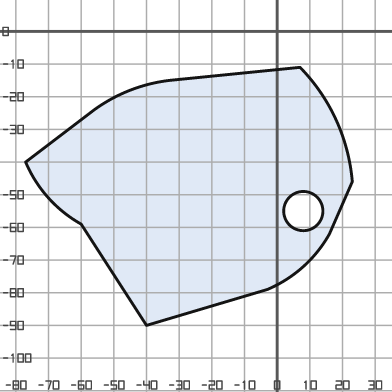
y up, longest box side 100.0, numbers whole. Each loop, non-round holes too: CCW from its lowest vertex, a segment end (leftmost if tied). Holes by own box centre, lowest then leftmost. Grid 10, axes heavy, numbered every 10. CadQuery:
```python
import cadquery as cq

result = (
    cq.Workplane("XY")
    .moveTo(-40.0, -90.0)
    .lineTo(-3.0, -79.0)
    .threePointArc((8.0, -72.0), (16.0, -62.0))
    .lineTo(23.0, -46.0)
    .threePointArc((18.0, -27.0), (7.0, -11.0))
    .lineTo(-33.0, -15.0)
    .threePointArc((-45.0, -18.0), (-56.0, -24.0))
    .lineTo(-77.0, -40.0)
    .threePointArc((-70.0, -51.0), (-60.0, -59.0))
    .close()
    .moveTo(8.0, -55.0)
    .circle(6.0)
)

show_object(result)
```